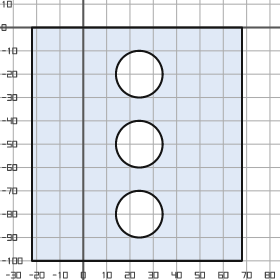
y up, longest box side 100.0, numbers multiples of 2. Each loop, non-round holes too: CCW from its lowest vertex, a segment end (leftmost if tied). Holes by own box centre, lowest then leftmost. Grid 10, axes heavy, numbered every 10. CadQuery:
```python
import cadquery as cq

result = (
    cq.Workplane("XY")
    .moveTo(-22.0, -100.0)
    .lineTo(68.0, -100.0)
    .lineTo(68.0, 0.0)
    .lineTo(-22.0, 0.0)
    .close()
    .moveTo(24.0, -80.0)
    .circle(10.0)
    .moveTo(24.0, -50.0)
    .circle(10.0)
    .moveTo(24.0, -20.0)
    .circle(10.0)
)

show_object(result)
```